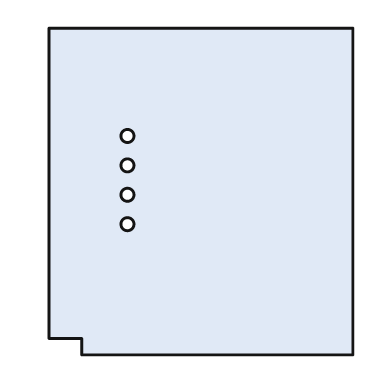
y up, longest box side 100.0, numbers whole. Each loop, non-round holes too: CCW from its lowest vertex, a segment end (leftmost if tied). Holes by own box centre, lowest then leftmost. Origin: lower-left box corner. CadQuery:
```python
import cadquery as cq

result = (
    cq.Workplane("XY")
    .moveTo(10.0, 0.0)
    .lineTo(93.0, 0.0)
    .lineTo(93.0, 100.0)
    .lineTo(0.0, 100.0)
    .lineTo(0.0, 5.0)
    .lineTo(10.0, 5.0)
    .close()
    .moveTo(24.0, 40.0)
    .circle(2.0)
    .moveTo(24.0, 49.0)
    .circle(2.0)
    .moveTo(24.0, 58.0)
    .circle(2.0)
    .moveTo(24.0, 67.0)
    .circle(2.0)
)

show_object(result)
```